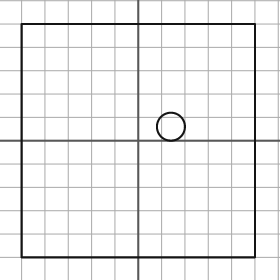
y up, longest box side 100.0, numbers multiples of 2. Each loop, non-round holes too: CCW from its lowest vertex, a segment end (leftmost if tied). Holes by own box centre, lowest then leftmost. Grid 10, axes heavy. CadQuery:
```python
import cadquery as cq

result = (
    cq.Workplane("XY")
    .moveTo(-50.0, -50.0)
    .lineTo(50.0, -50.0)
    .lineTo(50.0, 50.0)
    .lineTo(-50.0, 50.0)
    .close()
    .moveTo(14.0, 6.0)
    .circle(6.0)
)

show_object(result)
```